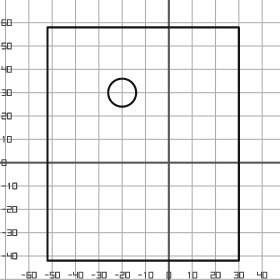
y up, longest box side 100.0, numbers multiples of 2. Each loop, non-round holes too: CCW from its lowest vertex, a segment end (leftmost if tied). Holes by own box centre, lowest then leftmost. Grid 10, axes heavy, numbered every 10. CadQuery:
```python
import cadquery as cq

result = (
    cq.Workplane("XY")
    .moveTo(-52.0, -42.0)
    .lineTo(30.0, -42.0)
    .lineTo(30.0, 58.0)
    .lineTo(-52.0, 58.0)
    .close()
    .moveTo(-20.0, 30.0)
    .circle(6.0)
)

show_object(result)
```